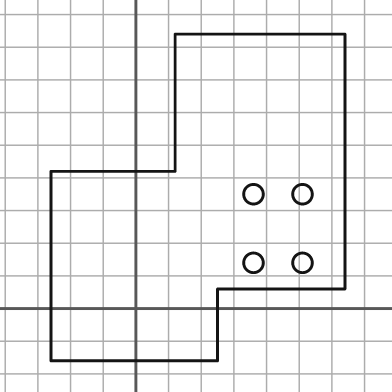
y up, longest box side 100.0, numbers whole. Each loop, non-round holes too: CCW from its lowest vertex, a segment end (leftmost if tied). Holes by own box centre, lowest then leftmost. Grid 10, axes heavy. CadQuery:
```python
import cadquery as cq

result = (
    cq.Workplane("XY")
    .moveTo(-26.0, -16.0)
    .lineTo(25.0, -16.0)
    .lineTo(25.0, 6.0)
    .lineTo(64.0, 6.0)
    .lineTo(64.0, 84.0)
    .lineTo(12.0, 84.0)
    .lineTo(12.0, 42.0)
    .lineTo(-26.0, 42.0)
    .close()
    .moveTo(36.0, 14.0)
    .circle(3.0)
    .moveTo(51.0, 14.0)
    .circle(3.0)
    .moveTo(36.0, 35.0)
    .circle(3.0)
    .moveTo(51.0, 35.0)
    .circle(3.0)
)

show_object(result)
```